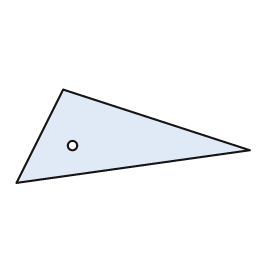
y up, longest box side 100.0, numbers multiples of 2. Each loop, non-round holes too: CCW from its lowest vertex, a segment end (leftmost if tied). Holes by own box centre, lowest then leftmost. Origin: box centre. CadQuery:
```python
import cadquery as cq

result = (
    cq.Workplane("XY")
    .moveTo(-50.0, -20.0)
    .lineTo(50.0, -6.0)
    .lineTo(-30.0, 20.0)
    .close()
    .moveTo(-26.0, -4.0)
    .circle(2.0)
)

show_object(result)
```